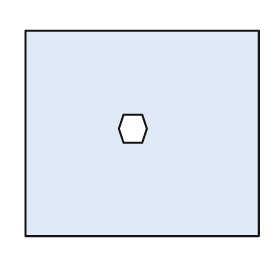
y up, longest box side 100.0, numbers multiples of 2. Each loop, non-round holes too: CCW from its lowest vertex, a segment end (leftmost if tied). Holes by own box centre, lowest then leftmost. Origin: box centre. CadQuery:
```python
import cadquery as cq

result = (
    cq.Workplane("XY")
    .moveTo(-50.0, -44.0)
    .lineTo(50.0, -44.0)
    .lineTo(50.0, 44.0)
    .lineTo(-50.0, 44.0)
    .close()
    .moveTo(-8.0, -4.0)
    .lineTo(0.0, -4.0)
    .lineTo(2.0, 2.0)
    .lineTo(0.0, 8.0)
    .lineTo(-8.0, 8.0)
    .lineTo(-10.0, 2.0)
    .close()
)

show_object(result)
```